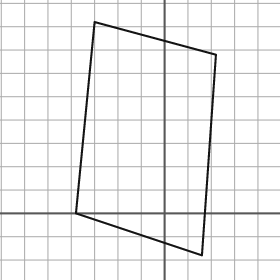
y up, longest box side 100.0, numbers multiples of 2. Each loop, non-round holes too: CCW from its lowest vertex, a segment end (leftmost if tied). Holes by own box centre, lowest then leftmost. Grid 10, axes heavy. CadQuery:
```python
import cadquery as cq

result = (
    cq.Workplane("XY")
    .moveTo(16.0, -18.0)
    .lineTo(22.0, 68.0)
    .lineTo(-30.0, 82.0)
    .lineTo(-38.0, 0.0)
    .close()
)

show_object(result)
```